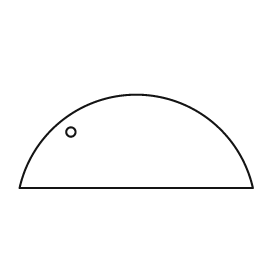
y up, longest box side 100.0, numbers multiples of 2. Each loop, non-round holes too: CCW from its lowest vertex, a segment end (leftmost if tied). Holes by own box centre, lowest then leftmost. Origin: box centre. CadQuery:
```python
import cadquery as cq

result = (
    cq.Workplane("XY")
    .moveTo(-50.0, -20.0)
    .lineTo(50.0, -20.0)
    .threePointArc((0.0, 20.0), (-50.0, -20.0))
    .close()
    .moveTo(-28.0, 4.0)
    .circle(2.0)
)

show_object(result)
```